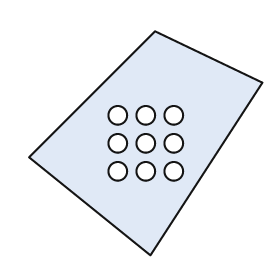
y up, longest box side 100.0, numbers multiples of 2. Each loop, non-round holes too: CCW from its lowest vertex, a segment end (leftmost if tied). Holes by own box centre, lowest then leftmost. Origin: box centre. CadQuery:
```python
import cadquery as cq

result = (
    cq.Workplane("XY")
    .moveTo(2.0, -48.0)
    .lineTo(50.0, 26.0)
    .lineTo(4.0, 48.0)
    .lineTo(-50.0, -6.0)
    .close()
    .moveTo(-12.0, -12.0)
    .circle(4.0)
    .moveTo(0.0, -12.0)
    .circle(4.0)
    .moveTo(12.0, -12.0)
    .circle(4.0)
    .moveTo(-12.0, 0.0)
    .circle(4.0)
    .moveTo(0.0, 0.0)
    .circle(4.0)
    .moveTo(12.0, 0.0)
    .circle(4.0)
    .moveTo(-12.0, 12.0)
    .circle(4.0)
    .moveTo(0.0, 12.0)
    .circle(4.0)
    .moveTo(12.0, 12.0)
    .circle(4.0)
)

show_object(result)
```